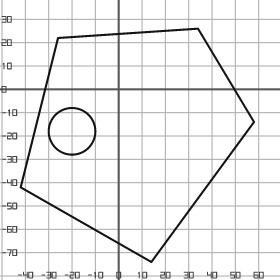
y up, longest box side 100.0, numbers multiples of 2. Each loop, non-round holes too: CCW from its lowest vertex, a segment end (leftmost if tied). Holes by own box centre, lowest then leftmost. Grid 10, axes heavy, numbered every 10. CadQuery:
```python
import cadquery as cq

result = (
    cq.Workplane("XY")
    .moveTo(14.0, -74.0)
    .lineTo(58.0, -14.0)
    .lineTo(34.0, 26.0)
    .lineTo(-26.0, 22.0)
    .lineTo(-42.0, -42.0)
    .close()
    .moveTo(-20.0, -18.0)
    .circle(10.0)
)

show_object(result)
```